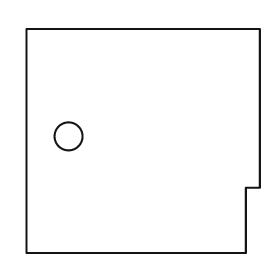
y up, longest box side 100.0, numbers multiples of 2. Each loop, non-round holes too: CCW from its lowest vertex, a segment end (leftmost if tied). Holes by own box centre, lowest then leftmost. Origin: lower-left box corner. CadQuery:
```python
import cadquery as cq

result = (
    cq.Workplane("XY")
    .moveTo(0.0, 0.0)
    .lineTo(94.0, 0.0)
    .lineTo(94.0, 28.0)
    .lineTo(100.0, 28.0)
    .lineTo(100.0, 96.0)
    .lineTo(0.0, 96.0)
    .close()
    .moveTo(18.0, 50.0)
    .circle(6.0)
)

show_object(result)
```